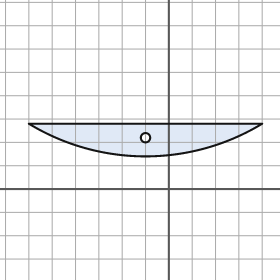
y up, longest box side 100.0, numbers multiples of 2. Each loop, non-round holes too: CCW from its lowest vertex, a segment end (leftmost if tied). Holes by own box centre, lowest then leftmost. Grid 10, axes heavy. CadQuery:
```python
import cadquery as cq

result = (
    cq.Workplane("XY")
    .moveTo(-60.0, 28.0)
    .threePointArc((-10.0, 14.0), (40.0, 28.0))
    .close()
    .moveTo(-10.0, 22.0)
    .circle(2.0)
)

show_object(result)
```